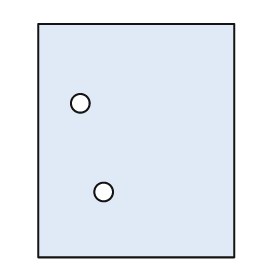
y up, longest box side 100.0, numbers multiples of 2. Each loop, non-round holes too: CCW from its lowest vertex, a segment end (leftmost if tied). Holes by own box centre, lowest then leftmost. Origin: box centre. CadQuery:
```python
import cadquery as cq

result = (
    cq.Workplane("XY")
    .moveTo(-42.0, -50.0)
    .lineTo(42.0, -50.0)
    .lineTo(42.0, 50.0)
    .lineTo(-42.0, 50.0)
    .close()
    .moveTo(-14.0, -22.0)
    .circle(4.0)
    .moveTo(-24.0, 16.0)
    .circle(4.0)
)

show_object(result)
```